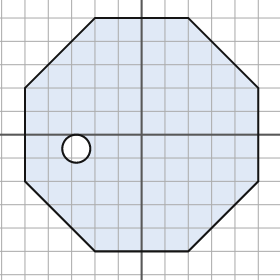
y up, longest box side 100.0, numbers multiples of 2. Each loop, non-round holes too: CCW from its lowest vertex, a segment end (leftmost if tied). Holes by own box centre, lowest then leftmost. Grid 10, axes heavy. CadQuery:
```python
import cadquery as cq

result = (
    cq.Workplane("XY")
    .moveTo(-20.0, -50.0)
    .lineTo(20.0, -50.0)
    .lineTo(50.0, -20.0)
    .lineTo(50.0, 20.0)
    .lineTo(20.0, 50.0)
    .lineTo(-20.0, 50.0)
    .lineTo(-50.0, 20.0)
    .lineTo(-50.0, -20.0)
    .close()
    .moveTo(-28.0, -6.0)
    .circle(6.0)
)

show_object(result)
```